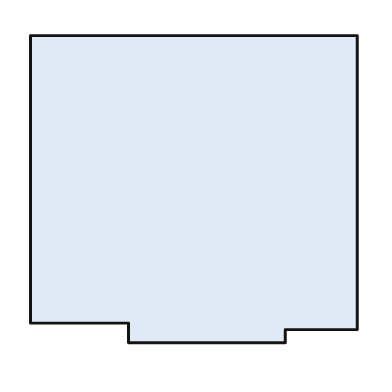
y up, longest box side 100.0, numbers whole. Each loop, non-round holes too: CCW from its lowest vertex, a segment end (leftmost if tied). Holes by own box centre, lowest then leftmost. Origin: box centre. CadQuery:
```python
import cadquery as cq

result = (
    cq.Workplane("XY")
    .moveTo(-20.0, -47.0)
    .lineTo(28.0, -47.0)
    .lineTo(28.0, -43.0)
    .lineTo(50.0, -43.0)
    .lineTo(50.0, 47.0)
    .lineTo(-50.0, 47.0)
    .lineTo(-50.0, -41.0)
    .lineTo(-20.0, -41.0)
    .close()
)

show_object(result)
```